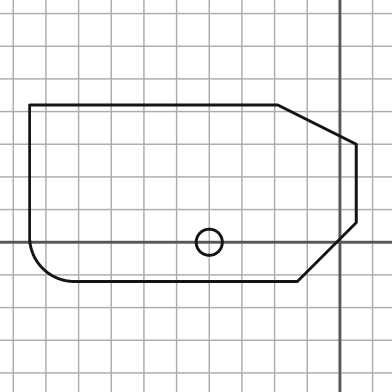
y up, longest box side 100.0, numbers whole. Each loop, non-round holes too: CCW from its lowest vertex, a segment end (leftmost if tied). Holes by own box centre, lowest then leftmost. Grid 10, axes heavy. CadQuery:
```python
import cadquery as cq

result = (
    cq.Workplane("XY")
    .moveTo(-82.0, -12.0)
    .lineTo(-13.0, -12.0)
    .lineTo(5.0, 6.0)
    .lineTo(5.0, 30.0)
    .lineTo(-19.0, 42.0)
    .lineTo(-95.0, 42.0)
    .lineTo(-95.0, 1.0)
    .threePointArc((-91.0, -8.0), (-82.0, -12.0))
    .close()
    .moveTo(-40.0, 0.0)
    .circle(4.0)
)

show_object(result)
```